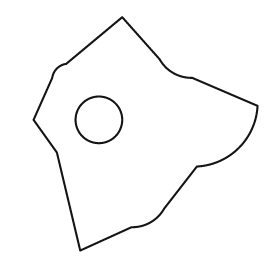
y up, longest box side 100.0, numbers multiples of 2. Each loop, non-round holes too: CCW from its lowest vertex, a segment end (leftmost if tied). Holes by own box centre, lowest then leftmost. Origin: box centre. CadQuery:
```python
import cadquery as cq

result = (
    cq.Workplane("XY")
    .moveTo(-28.0, -50.0)
    .lineTo(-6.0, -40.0)
    .threePointArc((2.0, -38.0), (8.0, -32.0))
    .lineTo(22.0, -14.0)
    .threePointArc((40.0, -6.0), (48.0, 12.0))
    .lineTo(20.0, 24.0)
    .threePointArc((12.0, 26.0), (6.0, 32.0))
    .lineTo(-10.0, 50.0)
    .lineTo(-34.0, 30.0)
    .threePointArc((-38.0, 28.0), (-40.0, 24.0))
    .lineTo(-48.0, 6.0)
    .lineTo(-38.0, -8.0)
    .close()
    .moveTo(-20.0, 6.0)
    .circle(10.0)
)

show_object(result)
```